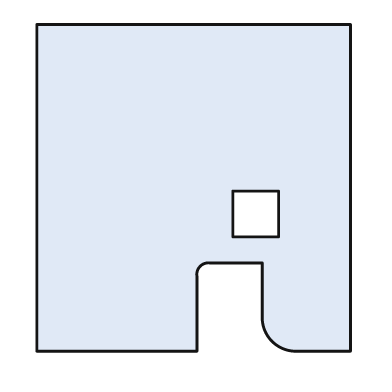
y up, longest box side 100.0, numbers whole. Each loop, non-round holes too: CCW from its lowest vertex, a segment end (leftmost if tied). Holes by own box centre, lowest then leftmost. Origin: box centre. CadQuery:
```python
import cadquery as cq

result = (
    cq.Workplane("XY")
    .moveTo(-48.0, -50.0)
    .lineTo(1.0, -50.0)
    .lineTo(1.0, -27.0)
    .threePointArc((2.0, -24.0), (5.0, -23.0))
    .lineTo(21.0, -23.0)
    .lineTo(21.0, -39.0)
    .threePointArc((24.0, -47.0), (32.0, -50.0))
    .lineTo(48.0, -50.0)
    .lineTo(48.0, 50.0)
    .lineTo(-48.0, 50.0)
    .close()
    .moveTo(12.0, -15.0)
    .lineTo(26.0, -15.0)
    .lineTo(26.0, -1.0)
    .lineTo(12.0, -1.0)
    .close()
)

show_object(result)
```